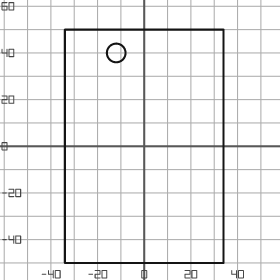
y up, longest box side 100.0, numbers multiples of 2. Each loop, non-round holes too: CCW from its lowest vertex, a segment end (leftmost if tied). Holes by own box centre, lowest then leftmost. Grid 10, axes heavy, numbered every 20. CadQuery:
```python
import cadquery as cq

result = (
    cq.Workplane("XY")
    .moveTo(-34.0, -50.0)
    .lineTo(34.0, -50.0)
    .lineTo(34.0, 50.0)
    .lineTo(-34.0, 50.0)
    .close()
    .moveTo(-12.0, 40.0)
    .circle(4.0)
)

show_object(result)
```